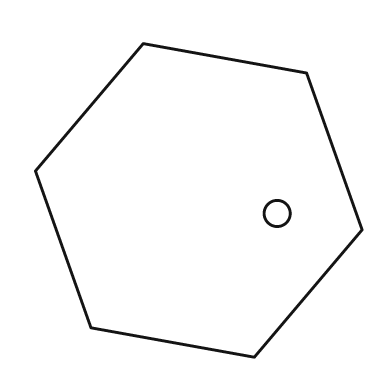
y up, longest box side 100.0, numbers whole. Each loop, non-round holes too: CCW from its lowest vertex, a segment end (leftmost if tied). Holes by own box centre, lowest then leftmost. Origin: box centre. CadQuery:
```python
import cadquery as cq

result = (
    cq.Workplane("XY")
    .moveTo(17.0, -48.0)
    .lineTo(50.0, -9.0)
    .lineTo(33.0, 39.0)
    .lineTo(-17.0, 48.0)
    .lineTo(-50.0, 9.0)
    .lineTo(-33.0, -39.0)
    .close()
    .moveTo(24.0, -4.0)
    .circle(4.0)
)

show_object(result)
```